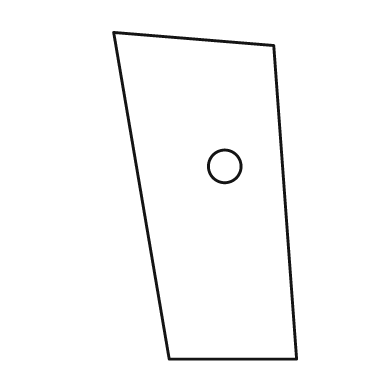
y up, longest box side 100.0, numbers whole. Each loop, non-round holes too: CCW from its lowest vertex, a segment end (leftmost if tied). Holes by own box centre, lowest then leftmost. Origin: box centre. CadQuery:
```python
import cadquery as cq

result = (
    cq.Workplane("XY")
    .moveTo(-11.0, -50.0)
    .lineTo(28.0, -50.0)
    .lineTo(21.0, 46.0)
    .lineTo(-28.0, 50.0)
    .close()
    .moveTo(6.0, 9.0)
    .circle(5.0)
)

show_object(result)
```